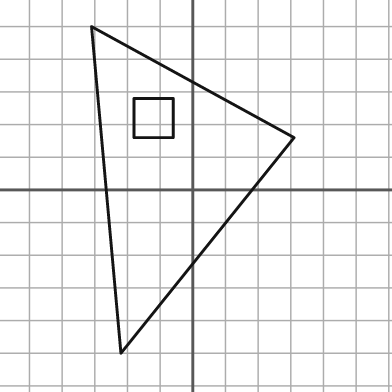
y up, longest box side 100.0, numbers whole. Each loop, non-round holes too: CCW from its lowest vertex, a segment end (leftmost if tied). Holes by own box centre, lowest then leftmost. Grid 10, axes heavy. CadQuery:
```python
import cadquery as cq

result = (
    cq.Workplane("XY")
    .moveTo(-22.0, -50.0)
    .lineTo(31.0, 16.0)
    .lineTo(-31.0, 50.0)
    .close()
    .moveTo(-18.0, 16.0)
    .lineTo(-6.0, 16.0)
    .lineTo(-6.0, 28.0)
    .lineTo(-18.0, 28.0)
    .close()
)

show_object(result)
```